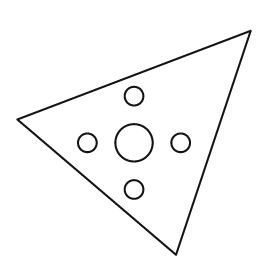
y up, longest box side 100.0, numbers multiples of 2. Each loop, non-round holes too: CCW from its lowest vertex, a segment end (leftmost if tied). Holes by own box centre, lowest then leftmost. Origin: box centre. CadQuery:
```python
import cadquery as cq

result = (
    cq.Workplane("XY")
    .moveTo(18.0, -48.0)
    .lineTo(50.0, 48.0)
    .lineTo(-50.0, 10.0)
    .close()
    .moveTo(0.0, -20.0)
    .circle(4.0)
    .moveTo(-20.0, 0.0)
    .circle(4.0)
    .moveTo(0.0, 0.0)
    .circle(8.0)
    .moveTo(20.0, 0.0)
    .circle(4.0)
    .moveTo(0.0, 20.0)
    .circle(4.0)
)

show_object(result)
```